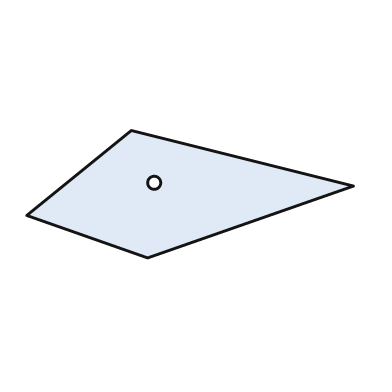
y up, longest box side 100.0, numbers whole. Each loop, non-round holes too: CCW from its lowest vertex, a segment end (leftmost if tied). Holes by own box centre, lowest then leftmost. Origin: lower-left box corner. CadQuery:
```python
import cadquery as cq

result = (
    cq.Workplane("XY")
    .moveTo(37.0, 0.0)
    .lineTo(100.0, 22.0)
    .lineTo(32.0, 39.0)
    .lineTo(0.0, 13.0)
    .close()
    .moveTo(39.0, 23.0)
    .circle(2.0)
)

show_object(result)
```